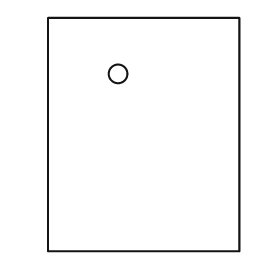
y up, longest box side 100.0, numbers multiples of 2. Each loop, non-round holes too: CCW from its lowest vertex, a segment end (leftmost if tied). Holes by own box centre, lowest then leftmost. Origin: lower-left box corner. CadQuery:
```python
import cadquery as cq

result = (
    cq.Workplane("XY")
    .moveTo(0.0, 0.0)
    .lineTo(82.0, 0.0)
    .lineTo(82.0, 100.0)
    .lineTo(0.0, 100.0)
    .close()
    .moveTo(30.0, 76.0)
    .circle(4.0)
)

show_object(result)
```